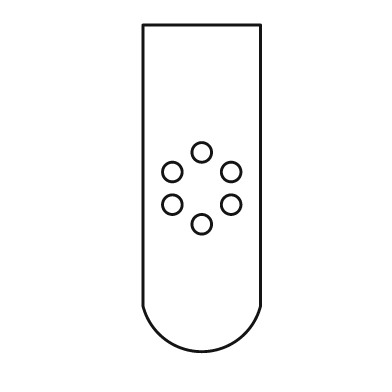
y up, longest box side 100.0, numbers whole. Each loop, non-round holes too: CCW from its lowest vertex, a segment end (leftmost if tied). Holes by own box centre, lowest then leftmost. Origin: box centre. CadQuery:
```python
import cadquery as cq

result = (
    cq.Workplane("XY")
    .moveTo(-18.0, -36.0)
    .threePointArc((0.0, -50.0), (18.0, -36.0))
    .lineTo(18.0, 50.0)
    .lineTo(-18.0, 50.0)
    .close()
    .moveTo(0.0, -11.0)
    .circle(3.0)
    .moveTo(-9.0, -5.0)
    .circle(3.0)
    .moveTo(9.0, -5.0)
    .circle(3.0)
    .moveTo(-9.0, 5.0)
    .circle(3.0)
    .moveTo(9.0, 5.0)
    .circle(3.0)
    .moveTo(0.0, 11.0)
    .circle(3.0)
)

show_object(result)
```